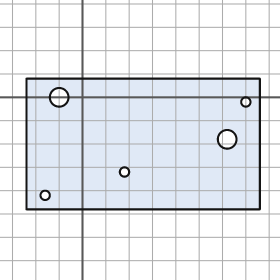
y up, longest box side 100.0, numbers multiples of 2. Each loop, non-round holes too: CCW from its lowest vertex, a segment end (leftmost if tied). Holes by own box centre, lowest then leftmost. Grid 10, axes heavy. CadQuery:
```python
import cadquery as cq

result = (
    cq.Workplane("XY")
    .moveTo(-24.0, -48.0)
    .lineTo(76.0, -48.0)
    .lineTo(76.0, 8.0)
    .lineTo(-24.0, 8.0)
    .close()
    .moveTo(-16.0, -42.0)
    .circle(2.0)
    .moveTo(18.0, -32.0)
    .circle(2.0)
    .moveTo(62.0, -18.0)
    .circle(4.0)
    .moveTo(70.0, -2.0)
    .circle(2.0)
    .moveTo(-10.0, 0.0)
    .circle(4.0)
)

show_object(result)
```